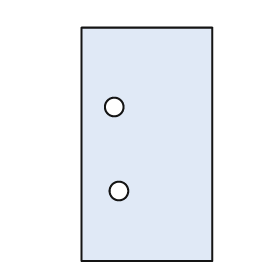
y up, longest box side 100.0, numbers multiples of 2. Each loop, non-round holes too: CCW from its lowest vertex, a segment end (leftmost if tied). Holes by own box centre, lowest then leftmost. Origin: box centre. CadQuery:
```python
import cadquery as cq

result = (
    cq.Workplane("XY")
    .moveTo(-28.0, -50.0)
    .lineTo(28.0, -50.0)
    .lineTo(28.0, 50.0)
    .lineTo(-28.0, 50.0)
    .close()
    .moveTo(-12.0, -20.0)
    .circle(4.0)
    .moveTo(-14.0, 16.0)
    .circle(4.0)
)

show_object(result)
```